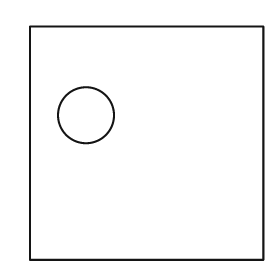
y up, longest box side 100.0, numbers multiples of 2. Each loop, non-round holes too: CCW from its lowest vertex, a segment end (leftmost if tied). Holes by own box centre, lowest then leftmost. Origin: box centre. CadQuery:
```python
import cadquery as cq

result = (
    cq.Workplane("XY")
    .moveTo(-50.0, -50.0)
    .lineTo(50.0, -50.0)
    .lineTo(50.0, 50.0)
    .lineTo(-50.0, 50.0)
    .close()
    .moveTo(-26.0, 12.0)
    .circle(12.0)
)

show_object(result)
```